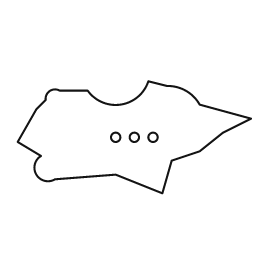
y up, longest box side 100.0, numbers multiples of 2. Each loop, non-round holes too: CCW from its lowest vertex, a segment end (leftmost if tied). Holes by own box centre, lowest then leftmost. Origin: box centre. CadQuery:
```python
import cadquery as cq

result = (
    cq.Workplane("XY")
    .moveTo(12.0, -24.0)
    .lineTo(16.0, -10.0)
    .lineTo(28.0, -6.0)
    .lineTo(38.0, 2.0)
    .lineTo(50.0, 8.0)
    .lineTo(28.0, 14.0)
    .threePointArc((22.0, 20.0), (14.0, 22.0))
    .lineTo(6.0, 24.0)
    .threePointArc((-6.0, 14.0), (-20.0, 20.0))
    .lineTo(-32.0, 20.0)
    .threePointArc((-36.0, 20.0), (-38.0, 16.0))
    .lineTo(-42.0, 12.0)
    .lineTo(-50.0, -2.0)
    .lineTo(-40.0, -8.0)
    .threePointArc((-42.0, -16.0), (-34.0, -18.0))
    .lineTo(-8.0, -16.0)
    .close()
    .moveTo(-8.0, 0.0)
    .circle(2.0)
    .moveTo(0.0, 0.0)
    .circle(2.0)
    .moveTo(8.0, 0.0)
    .circle(2.0)
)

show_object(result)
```